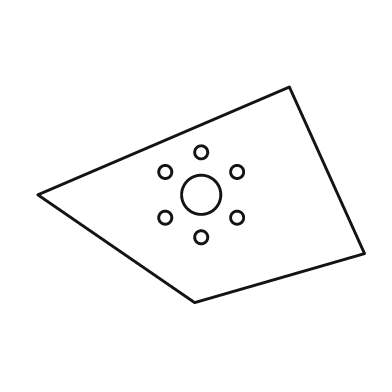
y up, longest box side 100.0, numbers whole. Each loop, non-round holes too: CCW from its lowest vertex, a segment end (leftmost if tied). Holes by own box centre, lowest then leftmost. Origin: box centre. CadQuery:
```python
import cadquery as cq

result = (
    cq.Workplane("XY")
    .moveTo(-2.0, -33.0)
    .lineTo(50.0, -18.0)
    .lineTo(27.0, 33.0)
    .lineTo(-50.0, 0.0)
    .close()
    .moveTo(0.0, -13.0)
    .circle(2.0)
    .moveTo(-11.0, -7.0)
    .circle(2.0)
    .moveTo(11.0, -7.0)
    .circle(2.0)
    .moveTo(0.0, 0.0)
    .circle(6.0)
    .moveTo(-11.0, 7.0)
    .circle(2.0)
    .moveTo(11.0, 7.0)
    .circle(2.0)
    .moveTo(0.0, 13.0)
    .circle(2.0)
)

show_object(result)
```